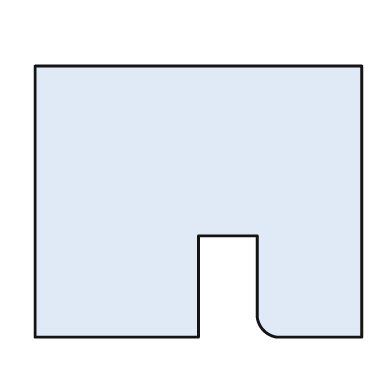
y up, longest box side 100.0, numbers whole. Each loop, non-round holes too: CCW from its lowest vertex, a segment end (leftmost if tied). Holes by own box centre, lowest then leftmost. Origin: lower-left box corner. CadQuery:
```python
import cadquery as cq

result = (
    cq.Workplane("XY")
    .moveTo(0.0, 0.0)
    .lineTo(50.0, 0.0)
    .lineTo(50.0, 31.0)
    .lineTo(68.0, 31.0)
    .lineTo(68.0, 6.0)
    .threePointArc((70.0, 2.0), (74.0, 0.0))
    .lineTo(100.0, 0.0)
    .lineTo(100.0, 83.0)
    .lineTo(0.0, 83.0)
    .close()
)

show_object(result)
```